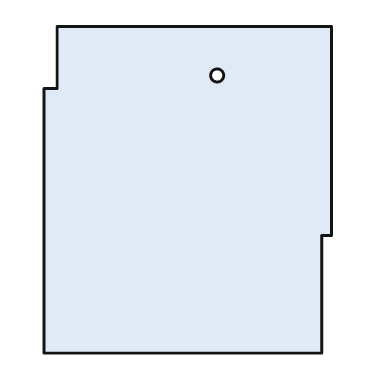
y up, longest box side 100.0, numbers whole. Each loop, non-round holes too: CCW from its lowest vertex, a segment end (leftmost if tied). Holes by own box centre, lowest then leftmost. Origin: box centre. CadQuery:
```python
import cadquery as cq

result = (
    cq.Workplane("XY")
    .moveTo(-44.0, -50.0)
    .lineTo(41.0, -50.0)
    .lineTo(41.0, -14.0)
    .lineTo(44.0, -14.0)
    .lineTo(44.0, 50.0)
    .lineTo(-40.0, 50.0)
    .lineTo(-40.0, 31.0)
    .lineTo(-44.0, 31.0)
    .close()
    .moveTo(9.0, 35.0)
    .circle(2.0)
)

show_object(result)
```